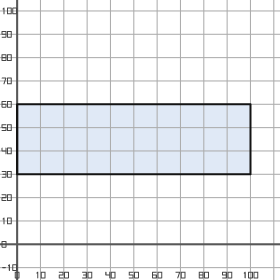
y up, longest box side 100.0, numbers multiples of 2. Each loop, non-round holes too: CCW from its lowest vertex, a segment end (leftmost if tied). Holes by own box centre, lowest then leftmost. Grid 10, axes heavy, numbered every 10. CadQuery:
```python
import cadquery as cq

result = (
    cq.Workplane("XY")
    .moveTo(0.0, 30.0)
    .lineTo(100.0, 30.0)
    .lineTo(100.0, 60.0)
    .lineTo(0.0, 60.0)
    .close()
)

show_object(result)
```